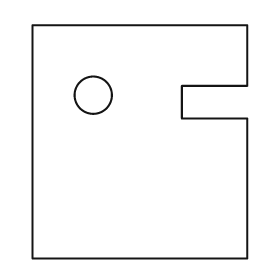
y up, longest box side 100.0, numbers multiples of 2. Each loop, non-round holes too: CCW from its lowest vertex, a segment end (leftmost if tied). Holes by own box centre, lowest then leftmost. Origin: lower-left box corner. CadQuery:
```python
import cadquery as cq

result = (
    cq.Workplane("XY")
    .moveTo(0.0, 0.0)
    .lineTo(92.0, 0.0)
    .lineTo(92.0, 60.0)
    .lineTo(64.0, 60.0)
    .lineTo(64.0, 74.0)
    .lineTo(92.0, 74.0)
    .lineTo(92.0, 100.0)
    .lineTo(0.0, 100.0)
    .close()
    .moveTo(26.0, 70.0)
    .circle(8.0)
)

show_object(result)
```